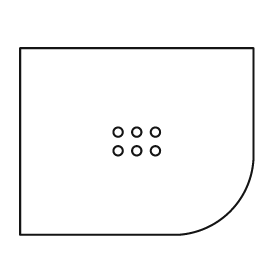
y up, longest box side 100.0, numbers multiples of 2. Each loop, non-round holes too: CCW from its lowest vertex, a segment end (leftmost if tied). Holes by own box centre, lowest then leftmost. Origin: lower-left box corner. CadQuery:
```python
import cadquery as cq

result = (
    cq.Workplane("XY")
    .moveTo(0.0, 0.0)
    .lineTo(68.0, 0.0)
    .threePointArc((90.0, 10.0), (100.0, 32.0))
    .lineTo(100.0, 80.0)
    .lineTo(0.0, 80.0)
    .close()
    .moveTo(42.0, 36.0)
    .circle(2.0)
    .moveTo(50.0, 36.0)
    .circle(2.0)
    .moveTo(58.0, 36.0)
    .circle(2.0)
    .moveTo(42.0, 44.0)
    .circle(2.0)
    .moveTo(50.0, 44.0)
    .circle(2.0)
    .moveTo(58.0, 44.0)
    .circle(2.0)
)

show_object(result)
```